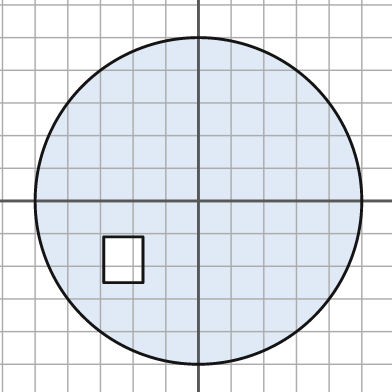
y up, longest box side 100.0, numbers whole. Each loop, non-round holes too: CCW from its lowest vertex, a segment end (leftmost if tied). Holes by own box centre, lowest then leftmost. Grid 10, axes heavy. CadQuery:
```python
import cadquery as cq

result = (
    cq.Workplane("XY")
    .moveTo(0.0, 0.0)
    .circle(50.0)
    .moveTo(-29.0, -25.0)
    .lineTo(-17.0, -25.0)
    .lineTo(-17.0, -11.0)
    .lineTo(-29.0, -11.0)
    .close()
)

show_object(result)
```